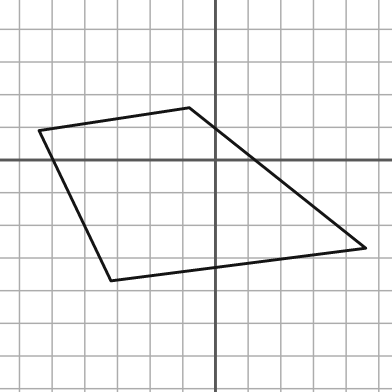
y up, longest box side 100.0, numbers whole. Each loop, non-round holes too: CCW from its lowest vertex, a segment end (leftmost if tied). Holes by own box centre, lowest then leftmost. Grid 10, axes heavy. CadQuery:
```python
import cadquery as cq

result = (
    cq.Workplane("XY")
    .moveTo(-32.0, -37.0)
    .lineTo(46.0, -27.0)
    .lineTo(-8.0, 16.0)
    .lineTo(-54.0, 9.0)
    .close()
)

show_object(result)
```